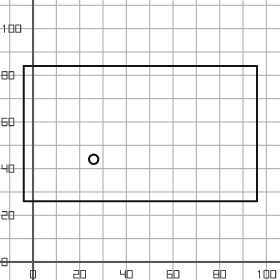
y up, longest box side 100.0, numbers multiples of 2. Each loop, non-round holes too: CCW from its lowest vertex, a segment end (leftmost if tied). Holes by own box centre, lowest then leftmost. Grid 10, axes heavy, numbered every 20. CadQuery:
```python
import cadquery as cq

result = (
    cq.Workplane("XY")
    .moveTo(-4.0, 26.0)
    .lineTo(96.0, 26.0)
    .lineTo(96.0, 84.0)
    .lineTo(-4.0, 84.0)
    .close()
    .moveTo(26.0, 44.0)
    .circle(2.0)
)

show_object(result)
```